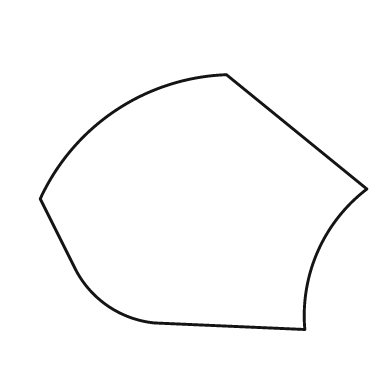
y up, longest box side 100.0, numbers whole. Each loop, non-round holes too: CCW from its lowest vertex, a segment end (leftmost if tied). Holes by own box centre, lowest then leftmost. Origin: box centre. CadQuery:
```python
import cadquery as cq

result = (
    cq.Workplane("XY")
    .moveTo(31.0, -39.0)
    .threePointArc((35.0, -15.0), (50.0, 4.0))
    .lineTo(7.0, 39.0)
    .threePointArc((-27.0, 28.0), (-50.0, 1.0))
    .lineTo(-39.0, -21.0)
    .threePointArc((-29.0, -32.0), (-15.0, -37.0))
    .close()
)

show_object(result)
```